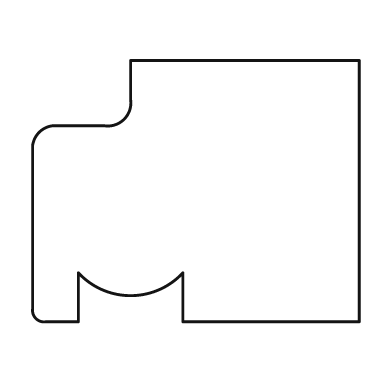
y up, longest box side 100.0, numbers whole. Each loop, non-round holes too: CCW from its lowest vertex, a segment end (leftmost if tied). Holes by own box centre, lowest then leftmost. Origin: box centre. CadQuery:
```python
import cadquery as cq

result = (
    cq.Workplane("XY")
    .moveTo(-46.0, -40.0)
    .lineTo(-36.0, -40.0)
    .lineTo(-36.0, -25.0)
    .threePointArc((-20.0, -32.0), (-4.0, -25.0))
    .lineTo(-4.0, -40.0)
    .lineTo(50.0, -40.0)
    .lineTo(50.0, 40.0)
    .lineTo(-20.0, 40.0)
    .lineTo(-20.0, 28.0)
    .threePointArc((-22.0, 22.0), (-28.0, 20.0))
    .lineTo(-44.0, 20.0)
    .threePointArc((-48.0, 18.0), (-50.0, 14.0))
    .lineTo(-50.0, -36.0)
    .threePointArc((-49.0, -39.0), (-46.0, -40.0))
    .close()
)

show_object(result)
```